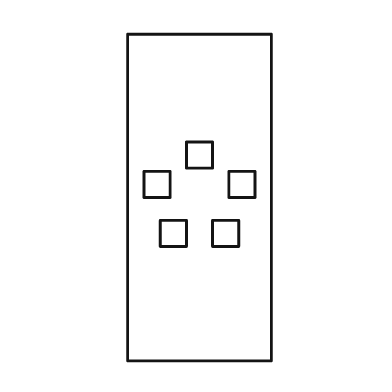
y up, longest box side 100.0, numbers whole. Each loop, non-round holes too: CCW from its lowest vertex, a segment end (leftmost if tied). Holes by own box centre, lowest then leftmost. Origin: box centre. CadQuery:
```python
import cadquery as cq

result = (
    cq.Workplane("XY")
    .moveTo(-22.0, -50.0)
    .lineTo(22.0, -50.0)
    .lineTo(22.0, 50.0)
    .lineTo(-22.0, 50.0)
    .close()
    .moveTo(-12.0, -15.0)
    .lineTo(-4.0, -15.0)
    .lineTo(-4.0, -7.0)
    .lineTo(-12.0, -7.0)
    .close()
    .moveTo(4.0, -15.0)
    .lineTo(12.0, -15.0)
    .lineTo(12.0, -7.0)
    .lineTo(4.0, -7.0)
    .close()
    .moveTo(-17.0, 0.0)
    .lineTo(-9.0, 0.0)
    .lineTo(-9.0, 8.0)
    .lineTo(-17.0, 8.0)
    .close()
    .moveTo(9.0, 0.0)
    .lineTo(17.0, 0.0)
    .lineTo(17.0, 8.0)
    .lineTo(9.0, 8.0)
    .close()
    .moveTo(-4.0, 9.0)
    .lineTo(4.0, 9.0)
    .lineTo(4.0, 17.0)
    .lineTo(-4.0, 17.0)
    .close()
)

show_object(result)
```